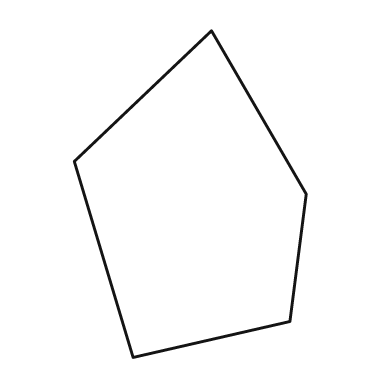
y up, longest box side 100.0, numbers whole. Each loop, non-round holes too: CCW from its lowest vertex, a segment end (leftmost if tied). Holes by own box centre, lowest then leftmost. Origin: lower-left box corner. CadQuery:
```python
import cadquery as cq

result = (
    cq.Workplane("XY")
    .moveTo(18.0, 0.0)
    .lineTo(66.0, 11.0)
    .lineTo(71.0, 50.0)
    .lineTo(42.0, 100.0)
    .lineTo(0.0, 60.0)
    .close()
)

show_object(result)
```